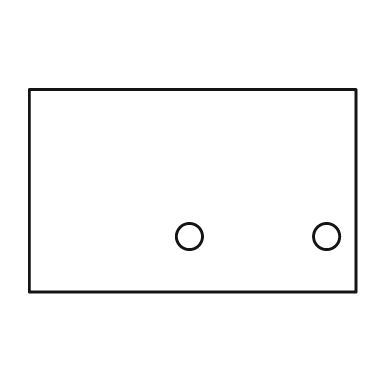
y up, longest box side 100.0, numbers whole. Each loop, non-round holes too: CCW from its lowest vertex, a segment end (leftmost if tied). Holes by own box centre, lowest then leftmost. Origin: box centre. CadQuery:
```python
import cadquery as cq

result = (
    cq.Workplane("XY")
    .moveTo(-50.0, -31.0)
    .lineTo(50.0, -31.0)
    .lineTo(50.0, 31.0)
    .lineTo(-50.0, 31.0)
    .close()
    .moveTo(-1.0, -14.0)
    .circle(4.0)
    .moveTo(41.0, -14.0)
    .circle(4.0)
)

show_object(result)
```